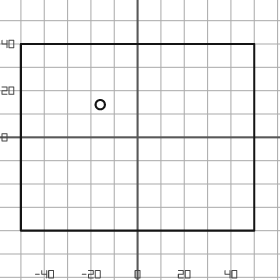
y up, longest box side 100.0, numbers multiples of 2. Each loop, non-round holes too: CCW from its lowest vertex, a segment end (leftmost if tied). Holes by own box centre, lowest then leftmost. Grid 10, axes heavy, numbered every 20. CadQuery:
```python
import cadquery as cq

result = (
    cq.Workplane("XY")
    .moveTo(-50.0, -40.0)
    .lineTo(50.0, -40.0)
    .lineTo(50.0, 40.0)
    .lineTo(-50.0, 40.0)
    .close()
    .moveTo(-16.0, 14.0)
    .circle(2.0)
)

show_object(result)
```